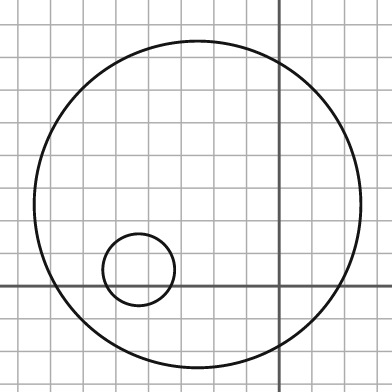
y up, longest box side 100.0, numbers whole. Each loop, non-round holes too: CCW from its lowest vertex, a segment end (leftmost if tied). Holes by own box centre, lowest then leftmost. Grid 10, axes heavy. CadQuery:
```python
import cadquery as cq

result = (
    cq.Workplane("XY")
    .moveTo(-25.0, 25.0)
    .circle(50.0)
    .moveTo(-43.0, 5.0)
    .circle(11.0)
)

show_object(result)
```